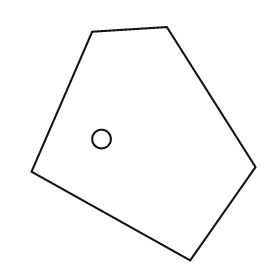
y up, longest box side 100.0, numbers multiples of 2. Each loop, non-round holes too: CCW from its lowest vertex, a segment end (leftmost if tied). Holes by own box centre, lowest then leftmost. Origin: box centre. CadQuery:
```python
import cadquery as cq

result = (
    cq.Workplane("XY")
    .moveTo(20.0, -50.0)
    .lineTo(48.0, -10.0)
    .lineTo(10.0, 50.0)
    .lineTo(-22.0, 48.0)
    .lineTo(-48.0, -12.0)
    .close()
    .moveTo(-18.0, 2.0)
    .circle(4.0)
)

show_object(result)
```